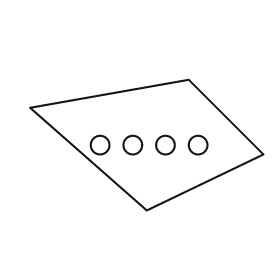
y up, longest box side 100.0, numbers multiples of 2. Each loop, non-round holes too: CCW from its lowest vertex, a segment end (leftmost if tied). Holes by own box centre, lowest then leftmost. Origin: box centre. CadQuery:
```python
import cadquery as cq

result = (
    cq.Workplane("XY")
    .moveTo(0.0, -28.0)
    .lineTo(50.0, -4.0)
    .lineTo(18.0, 28.0)
    .lineTo(-50.0, 16.0)
    .close()
    .moveTo(-20.0, 0.0)
    .circle(4.0)
    .moveTo(-6.0, 0.0)
    .circle(4.0)
    .moveTo(8.0, 0.0)
    .circle(4.0)
    .moveTo(22.0, 0.0)
    .circle(4.0)
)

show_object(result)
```